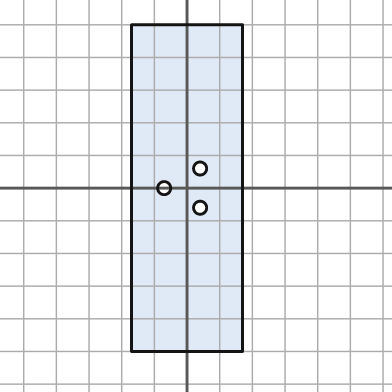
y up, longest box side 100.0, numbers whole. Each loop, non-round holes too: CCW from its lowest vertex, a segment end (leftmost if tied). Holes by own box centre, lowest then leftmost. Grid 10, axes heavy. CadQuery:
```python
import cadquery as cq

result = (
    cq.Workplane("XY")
    .moveTo(-17.0, -50.0)
    .lineTo(17.0, -50.0)
    .lineTo(17.0, 50.0)
    .lineTo(-17.0, 50.0)
    .close()
    .moveTo(4.0, -6.0)
    .circle(2.0)
    .moveTo(-7.0, 0.0)
    .circle(2.0)
    .moveTo(4.0, 6.0)
    .circle(2.0)
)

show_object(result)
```